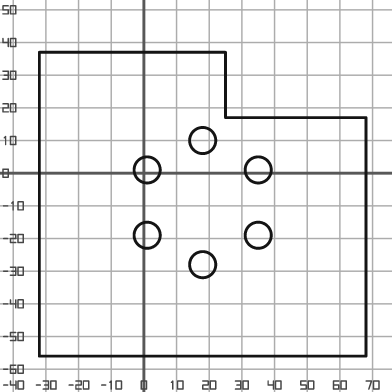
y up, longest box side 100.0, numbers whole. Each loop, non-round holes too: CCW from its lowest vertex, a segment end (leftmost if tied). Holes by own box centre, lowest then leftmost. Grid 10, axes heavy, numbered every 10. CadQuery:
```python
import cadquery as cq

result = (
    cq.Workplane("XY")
    .moveTo(-32.0, -56.0)
    .lineTo(68.0, -56.0)
    .lineTo(68.0, 17.0)
    .lineTo(25.0, 17.0)
    .lineTo(25.0, 37.0)
    .lineTo(-32.0, 37.0)
    .close()
    .moveTo(18.0, -28.0)
    .circle(4.0)
    .moveTo(1.0, -19.0)
    .circle(4.0)
    .moveTo(35.0, -19.0)
    .circle(4.0)
    .moveTo(1.0, 1.0)
    .circle(4.0)
    .moveTo(35.0, 1.0)
    .circle(4.0)
    .moveTo(18.0, 10.0)
    .circle(4.0)
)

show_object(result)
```